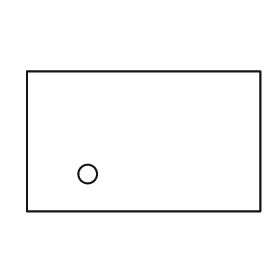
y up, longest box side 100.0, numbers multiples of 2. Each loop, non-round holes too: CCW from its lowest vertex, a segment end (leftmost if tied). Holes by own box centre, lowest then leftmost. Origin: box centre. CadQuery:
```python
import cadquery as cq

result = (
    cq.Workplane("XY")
    .moveTo(-50.0, -30.0)
    .lineTo(50.0, -30.0)
    .lineTo(50.0, 30.0)
    .lineTo(-50.0, 30.0)
    .close()
    .moveTo(-24.0, -14.0)
    .circle(4.0)
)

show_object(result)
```